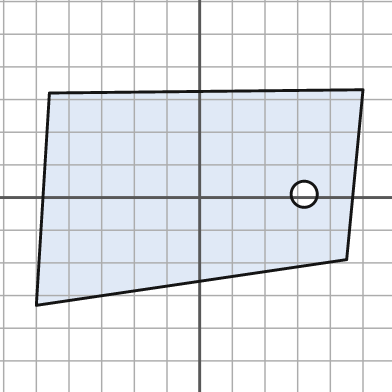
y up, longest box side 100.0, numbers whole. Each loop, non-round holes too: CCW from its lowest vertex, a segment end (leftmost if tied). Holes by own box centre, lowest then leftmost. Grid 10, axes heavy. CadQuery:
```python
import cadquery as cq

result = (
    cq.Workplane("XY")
    .moveTo(-50.0, -33.0)
    .lineTo(45.0, -19.0)
    .lineTo(50.0, 33.0)
    .lineTo(-46.0, 32.0)
    .close()
    .moveTo(32.0, 1.0)
    .circle(4.0)
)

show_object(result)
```